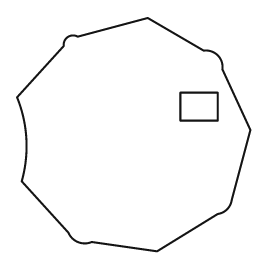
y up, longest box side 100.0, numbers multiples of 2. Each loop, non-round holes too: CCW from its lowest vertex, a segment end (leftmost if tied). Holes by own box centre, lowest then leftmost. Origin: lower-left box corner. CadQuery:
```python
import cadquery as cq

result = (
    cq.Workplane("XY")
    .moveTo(60.0, 0.0)
    .lineTo(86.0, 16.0)
    .threePointArc((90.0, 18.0), (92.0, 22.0))
    .lineTo(100.0, 52.0)
    .lineTo(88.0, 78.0)
    .threePointArc((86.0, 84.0), (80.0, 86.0))
    .lineTo(56.0, 100.0)
    .lineTo(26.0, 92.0)
    .threePointArc((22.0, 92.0), (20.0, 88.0))
    .lineTo(0.0, 66.0)
    .threePointArc((4.0, 48.0), (2.0, 30.0))
    .lineTo(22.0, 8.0)
    .threePointArc((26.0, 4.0), (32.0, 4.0))
    .close()
    .moveTo(70.0, 56.0)
    .lineTo(86.0, 56.0)
    .lineTo(86.0, 68.0)
    .lineTo(70.0, 68.0)
    .close()
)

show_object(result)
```